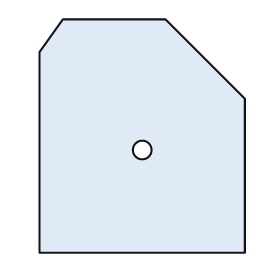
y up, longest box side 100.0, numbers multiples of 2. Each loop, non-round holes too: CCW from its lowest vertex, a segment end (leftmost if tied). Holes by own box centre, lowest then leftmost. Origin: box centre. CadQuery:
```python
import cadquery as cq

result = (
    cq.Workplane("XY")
    .moveTo(-44.0, -50.0)
    .lineTo(44.0, -50.0)
    .lineTo(44.0, 16.0)
    .lineTo(10.0, 50.0)
    .lineTo(-34.0, 50.0)
    .lineTo(-44.0, 36.0)
    .close()
    .moveTo(0.0, -6.0)
    .circle(4.0)
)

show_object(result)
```